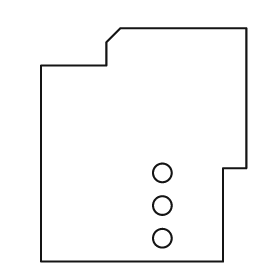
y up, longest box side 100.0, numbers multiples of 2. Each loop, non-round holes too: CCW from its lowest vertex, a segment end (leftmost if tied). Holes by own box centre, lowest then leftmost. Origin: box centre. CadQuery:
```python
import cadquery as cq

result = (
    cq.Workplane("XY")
    .moveTo(-44.0, -50.0)
    .lineTo(34.0, -50.0)
    .lineTo(34.0, -10.0)
    .lineTo(44.0, -10.0)
    .lineTo(44.0, 50.0)
    .lineTo(-10.0, 50.0)
    .lineTo(-16.0, 44.0)
    .lineTo(-16.0, 34.0)
    .lineTo(-44.0, 34.0)
    .close()
    .moveTo(8.0, -40.0)
    .circle(4.0)
    .moveTo(8.0, -26.0)
    .circle(4.0)
    .moveTo(8.0, -12.0)
    .circle(4.0)
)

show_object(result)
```